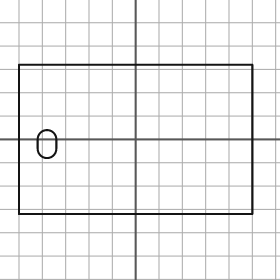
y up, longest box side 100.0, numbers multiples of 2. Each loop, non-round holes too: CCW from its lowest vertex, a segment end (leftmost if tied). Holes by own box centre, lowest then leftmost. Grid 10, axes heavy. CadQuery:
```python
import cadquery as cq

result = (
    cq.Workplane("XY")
    .moveTo(-50.0, -32.0)
    .lineTo(50.0, -32.0)
    .lineTo(50.0, 32.0)
    .lineTo(-50.0, 32.0)
    .close()
    .moveTo(-42.0, -4.0)
    .threePointArc((-38.0, -8.0), (-34.0, -4.0))
    .lineTo(-34.0, 0.0)
    .threePointArc((-38.0, 4.0), (-42.0, 0.0))
    .close()
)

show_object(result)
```